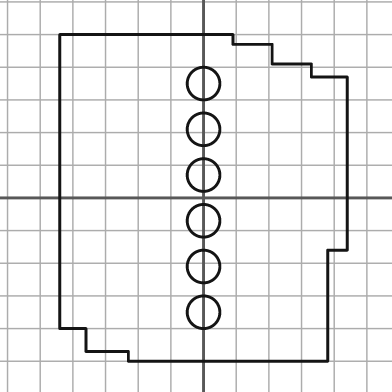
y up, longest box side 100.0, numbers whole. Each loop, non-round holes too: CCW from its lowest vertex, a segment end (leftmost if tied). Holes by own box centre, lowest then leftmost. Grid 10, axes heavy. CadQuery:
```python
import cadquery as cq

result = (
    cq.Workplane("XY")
    .moveTo(-23.0, -50.0)
    .lineTo(38.0, -50.0)
    .lineTo(38.0, -16.0)
    .lineTo(44.0, -16.0)
    .lineTo(44.0, 37.0)
    .lineTo(33.0, 37.0)
    .lineTo(33.0, 41.0)
    .lineTo(21.0, 41.0)
    .lineTo(21.0, 47.0)
    .lineTo(9.0, 47.0)
    .lineTo(9.0, 50.0)
    .lineTo(-44.0, 50.0)
    .lineTo(-44.0, -40.0)
    .lineTo(-36.0, -40.0)
    .lineTo(-36.0, -47.0)
    .lineTo(-23.0, -47.0)
    .close()
    .moveTo(0.0, -35.0)
    .circle(5.0)
    .moveTo(0.0, -21.0)
    .circle(5.0)
    .moveTo(0.0, -7.0)
    .circle(5.0)
    .moveTo(0.0, 7.0)
    .circle(5.0)
    .moveTo(0.0, 21.0)
    .circle(5.0)
    .moveTo(0.0, 35.0)
    .circle(5.0)
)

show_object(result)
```